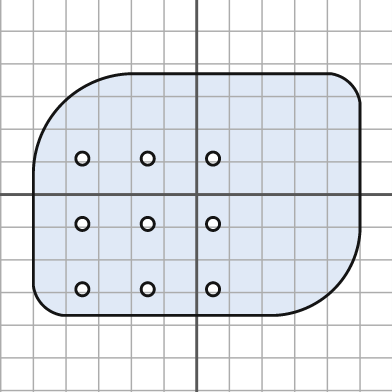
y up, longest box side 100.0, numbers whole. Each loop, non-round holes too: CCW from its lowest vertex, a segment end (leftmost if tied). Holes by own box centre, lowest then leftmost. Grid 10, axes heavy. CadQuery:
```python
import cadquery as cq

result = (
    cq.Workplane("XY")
    .moveTo(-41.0, -37.0)
    .lineTo(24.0, -37.0)
    .threePointArc((42.0, -29.0), (50.0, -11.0))
    .lineTo(50.0, 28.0)
    .threePointArc((47.0, 34.0), (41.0, 37.0))
    .lineTo(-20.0, 37.0)
    .threePointArc((-41.0, 28.0), (-50.0, 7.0))
    .lineTo(-50.0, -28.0)
    .threePointArc((-47.0, -34.0), (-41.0, -37.0))
    .close()
    .moveTo(-35.0, -29.0)
    .circle(2.0)
    .moveTo(-15.0, -29.0)
    .circle(2.0)
    .moveTo(5.0, -29.0)
    .circle(2.0)
    .moveTo(-35.0, -9.0)
    .circle(2.0)
    .moveTo(-15.0, -9.0)
    .circle(2.0)
    .moveTo(5.0, -9.0)
    .circle(2.0)
    .moveTo(-35.0, 11.0)
    .circle(2.0)
    .moveTo(-15.0, 11.0)
    .circle(2.0)
    .moveTo(5.0, 11.0)
    .circle(2.0)
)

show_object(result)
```